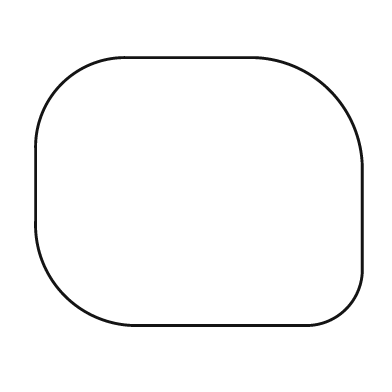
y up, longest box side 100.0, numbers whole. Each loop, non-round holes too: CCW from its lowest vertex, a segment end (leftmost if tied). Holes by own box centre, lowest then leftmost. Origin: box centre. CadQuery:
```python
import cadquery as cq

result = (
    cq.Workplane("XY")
    .moveTo(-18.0, -41.0)
    .lineTo(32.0, -41.0)
    .threePointArc((45.0, -36.0), (50.0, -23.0))
    .lineTo(50.0, 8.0)
    .threePointArc((40.0, 31.0), (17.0, 41.0))
    .lineTo(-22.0, 41.0)
    .threePointArc((-42.0, 33.0), (-50.0, 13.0))
    .lineTo(-50.0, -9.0)
    .threePointArc((-41.0, -32.0), (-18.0, -41.0))
    .close()
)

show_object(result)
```